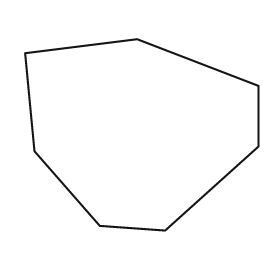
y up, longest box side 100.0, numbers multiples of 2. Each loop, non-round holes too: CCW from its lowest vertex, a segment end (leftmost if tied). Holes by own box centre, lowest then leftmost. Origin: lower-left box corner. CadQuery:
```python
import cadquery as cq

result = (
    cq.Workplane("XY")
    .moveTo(60.0, 0.0)
    .lineTo(100.0, 36.0)
    .lineTo(100.0, 62.0)
    .lineTo(48.0, 82.0)
    .lineTo(0.0, 76.0)
    .lineTo(4.0, 34.0)
    .lineTo(32.0, 2.0)
    .close()
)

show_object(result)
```